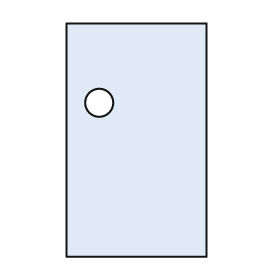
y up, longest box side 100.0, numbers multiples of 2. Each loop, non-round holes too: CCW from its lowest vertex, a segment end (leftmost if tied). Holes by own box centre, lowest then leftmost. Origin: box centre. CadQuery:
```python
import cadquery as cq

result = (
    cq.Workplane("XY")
    .moveTo(-30.0, -50.0)
    .lineTo(30.0, -50.0)
    .lineTo(30.0, 50.0)
    .lineTo(-30.0, 50.0)
    .close()
    .moveTo(-16.0, 16.0)
    .circle(6.0)
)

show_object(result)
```